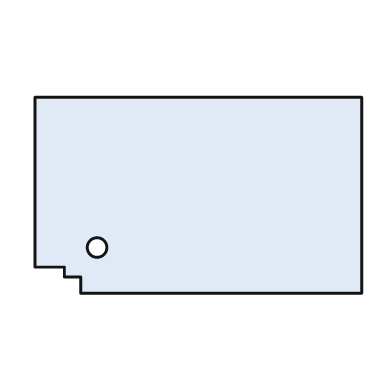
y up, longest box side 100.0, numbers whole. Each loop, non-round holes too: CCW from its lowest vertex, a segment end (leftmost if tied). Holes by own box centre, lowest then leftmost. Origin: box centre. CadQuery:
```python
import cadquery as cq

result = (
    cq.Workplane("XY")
    .moveTo(-36.0, -30.0)
    .lineTo(50.0, -30.0)
    .lineTo(50.0, 30.0)
    .lineTo(-50.0, 30.0)
    .lineTo(-50.0, -22.0)
    .lineTo(-41.0, -22.0)
    .lineTo(-41.0, -25.0)
    .lineTo(-36.0, -25.0)
    .close()
    .moveTo(-31.0, -16.0)
    .circle(3.0)
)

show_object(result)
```